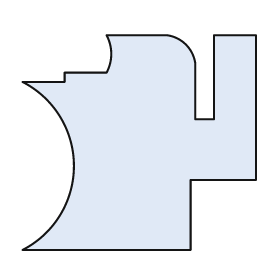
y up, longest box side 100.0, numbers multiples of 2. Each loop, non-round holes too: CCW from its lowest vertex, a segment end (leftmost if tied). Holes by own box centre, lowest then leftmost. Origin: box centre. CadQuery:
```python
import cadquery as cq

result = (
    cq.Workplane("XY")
    .moveTo(-50.0, -46.0)
    .lineTo(22.0, -46.0)
    .lineTo(22.0, -16.0)
    .lineTo(50.0, -16.0)
    .lineTo(50.0, 46.0)
    .lineTo(32.0, 46.0)
    .lineTo(32.0, 10.0)
    .lineTo(24.0, 10.0)
    .lineTo(24.0, 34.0)
    .threePointArc((20.0, 42.0), (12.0, 46.0))
    .lineTo(-14.0, 46.0)
    .threePointArc((-12.0, 38.0), (-14.0, 30.0))
    .lineTo(-32.0, 30.0)
    .lineTo(-32.0, 26.0)
    .lineTo(-50.0, 26.0)
    .threePointArc((-28.0, -10.0), (-50.0, -46.0))
    .close()
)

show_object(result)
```